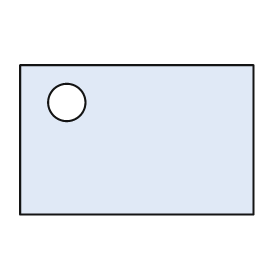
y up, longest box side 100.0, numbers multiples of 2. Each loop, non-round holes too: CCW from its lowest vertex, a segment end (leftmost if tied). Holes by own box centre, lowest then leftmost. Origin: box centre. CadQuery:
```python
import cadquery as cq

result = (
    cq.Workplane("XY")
    .moveTo(-50.0, -32.0)
    .lineTo(50.0, -32.0)
    .lineTo(50.0, 32.0)
    .lineTo(-50.0, 32.0)
    .close()
    .moveTo(-30.0, 16.0)
    .circle(8.0)
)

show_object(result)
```